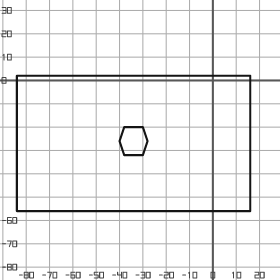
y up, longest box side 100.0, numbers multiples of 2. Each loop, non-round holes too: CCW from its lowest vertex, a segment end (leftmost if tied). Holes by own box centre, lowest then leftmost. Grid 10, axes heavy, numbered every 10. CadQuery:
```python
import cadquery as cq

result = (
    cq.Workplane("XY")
    .moveTo(-84.0, -56.0)
    .lineTo(16.0, -56.0)
    .lineTo(16.0, 2.0)
    .lineTo(-84.0, 2.0)
    .close()
    .moveTo(-38.0, -32.0)
    .lineTo(-30.0, -32.0)
    .lineTo(-28.0, -26.0)
    .lineTo(-30.0, -20.0)
    .lineTo(-38.0, -20.0)
    .lineTo(-40.0, -26.0)
    .close()
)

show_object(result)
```